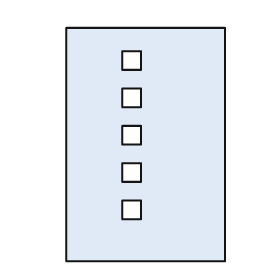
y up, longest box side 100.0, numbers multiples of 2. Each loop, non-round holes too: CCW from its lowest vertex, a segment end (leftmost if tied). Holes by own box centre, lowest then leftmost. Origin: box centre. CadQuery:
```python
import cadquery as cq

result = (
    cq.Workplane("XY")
    .moveTo(-34.0, -50.0)
    .lineTo(34.0, -50.0)
    .lineTo(34.0, 50.0)
    .lineTo(-34.0, 50.0)
    .close()
    .moveTo(-10.0, -32.0)
    .lineTo(-2.0, -32.0)
    .lineTo(-2.0, -24.0)
    .lineTo(-10.0, -24.0)
    .close()
    .moveTo(-10.0, -16.0)
    .lineTo(-2.0, -16.0)
    .lineTo(-2.0, -8.0)
    .lineTo(-10.0, -8.0)
    .close()
    .moveTo(-10.0, 0.0)
    .lineTo(-2.0, 0.0)
    .lineTo(-2.0, 8.0)
    .lineTo(-10.0, 8.0)
    .close()
    .moveTo(-10.0, 16.0)
    .lineTo(-2.0, 16.0)
    .lineTo(-2.0, 24.0)
    .lineTo(-10.0, 24.0)
    .close()
    .moveTo(-10.0, 32.0)
    .lineTo(-2.0, 32.0)
    .lineTo(-2.0, 40.0)
    .lineTo(-10.0, 40.0)
    .close()
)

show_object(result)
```